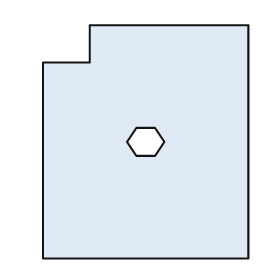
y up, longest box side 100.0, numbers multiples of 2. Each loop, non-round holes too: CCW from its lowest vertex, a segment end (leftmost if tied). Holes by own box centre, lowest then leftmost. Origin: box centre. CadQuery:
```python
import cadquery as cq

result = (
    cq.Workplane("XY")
    .moveTo(-44.0, -50.0)
    .lineTo(44.0, -50.0)
    .lineTo(44.0, 50.0)
    .lineTo(-24.0, 50.0)
    .lineTo(-24.0, 34.0)
    .lineTo(-44.0, 34.0)
    .close()
    .moveTo(-4.0, -6.0)
    .lineTo(4.0, -6.0)
    .lineTo(8.0, 0.0)
    .lineTo(4.0, 6.0)
    .lineTo(-4.0, 6.0)
    .lineTo(-8.0, 0.0)
    .close()
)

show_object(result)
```